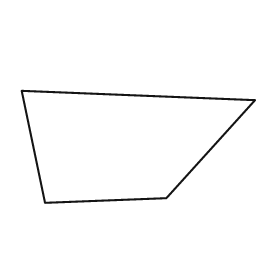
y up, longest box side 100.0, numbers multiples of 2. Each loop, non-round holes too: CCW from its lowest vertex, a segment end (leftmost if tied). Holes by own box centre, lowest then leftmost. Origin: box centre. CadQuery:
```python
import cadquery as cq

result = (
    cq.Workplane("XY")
    .moveTo(-40.0, -24.0)
    .lineTo(12.0, -22.0)
    .lineTo(50.0, 20.0)
    .lineTo(-50.0, 24.0)
    .close()
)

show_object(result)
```